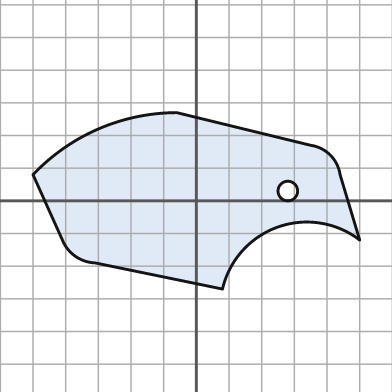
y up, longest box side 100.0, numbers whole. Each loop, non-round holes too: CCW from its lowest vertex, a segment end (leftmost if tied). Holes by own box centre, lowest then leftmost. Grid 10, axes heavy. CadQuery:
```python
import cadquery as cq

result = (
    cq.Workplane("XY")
    .moveTo(8.0, -27.0)
    .threePointArc((25.0, -8.0), (50.0, -12.0))
    .lineTo(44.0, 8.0)
    .threePointArc((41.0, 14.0), (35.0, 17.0))
    .lineTo(-6.0, 27.0)
    .threePointArc((-30.0, 22.0), (-50.0, 8.0))
    .lineTo(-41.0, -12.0)
    .threePointArc((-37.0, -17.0), (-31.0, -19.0))
    .close()
    .moveTo(28.0, 3.0)
    .circle(3.0)
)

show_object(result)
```